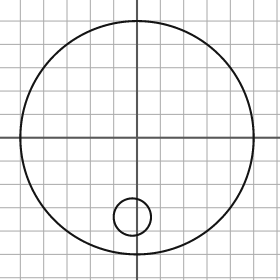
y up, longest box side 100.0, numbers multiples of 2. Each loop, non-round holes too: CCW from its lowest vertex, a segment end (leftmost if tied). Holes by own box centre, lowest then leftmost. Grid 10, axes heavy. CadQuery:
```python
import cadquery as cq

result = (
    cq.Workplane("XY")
    .moveTo(0.0, 0.0)
    .circle(50.0)
    .moveTo(-2.0, -34.0)
    .circle(8.0)
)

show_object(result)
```